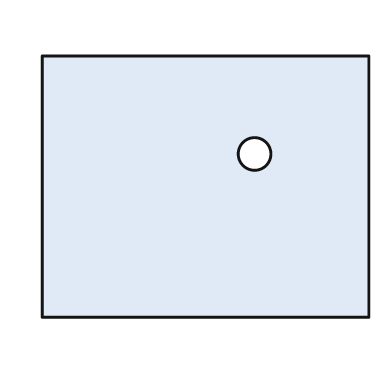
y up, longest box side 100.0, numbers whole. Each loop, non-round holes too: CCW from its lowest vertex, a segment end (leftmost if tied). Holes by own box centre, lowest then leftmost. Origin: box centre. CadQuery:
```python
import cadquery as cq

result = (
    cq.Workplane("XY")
    .moveTo(-50.0, -40.0)
    .lineTo(50.0, -40.0)
    .lineTo(50.0, 40.0)
    .lineTo(-50.0, 40.0)
    .close()
    .moveTo(15.0, 10.0)
    .circle(5.0)
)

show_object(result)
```